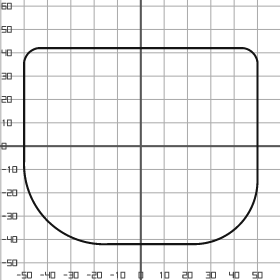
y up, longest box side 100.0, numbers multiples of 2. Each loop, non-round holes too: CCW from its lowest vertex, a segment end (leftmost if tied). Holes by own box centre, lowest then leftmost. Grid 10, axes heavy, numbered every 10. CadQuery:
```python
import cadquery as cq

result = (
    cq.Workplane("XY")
    .moveTo(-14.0, -42.0)
    .lineTo(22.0, -42.0)
    .threePointArc((42.0, -34.0), (50.0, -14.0))
    .lineTo(50.0, 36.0)
    .threePointArc((48.0, 40.0), (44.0, 42.0))
    .lineTo(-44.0, 42.0)
    .threePointArc((-48.0, 40.0), (-50.0, 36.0))
    .lineTo(-50.0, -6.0)
    .threePointArc((-40.0, -32.0), (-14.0, -42.0))
    .close()
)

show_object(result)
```